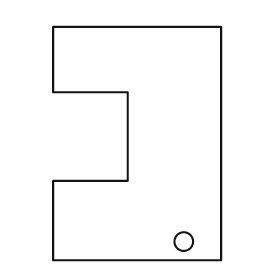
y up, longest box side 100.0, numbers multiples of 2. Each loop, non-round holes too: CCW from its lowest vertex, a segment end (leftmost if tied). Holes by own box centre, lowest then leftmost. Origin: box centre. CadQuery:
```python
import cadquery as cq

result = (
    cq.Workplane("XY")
    .moveTo(-36.0, -50.0)
    .lineTo(36.0, -50.0)
    .lineTo(36.0, 50.0)
    .lineTo(-36.0, 50.0)
    .lineTo(-36.0, 22.0)
    .lineTo(-4.0, 22.0)
    .lineTo(-4.0, -16.0)
    .lineTo(-36.0, -16.0)
    .close()
    .moveTo(20.0, -42.0)
    .circle(4.0)
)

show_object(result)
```